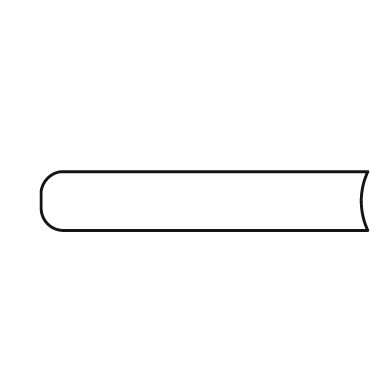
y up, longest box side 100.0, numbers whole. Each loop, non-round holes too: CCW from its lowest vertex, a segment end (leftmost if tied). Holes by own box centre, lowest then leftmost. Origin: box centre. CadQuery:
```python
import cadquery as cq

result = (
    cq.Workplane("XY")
    .moveTo(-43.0, -9.0)
    .lineTo(50.0, -9.0)
    .threePointArc((48.0, 0.0), (50.0, 9.0))
    .lineTo(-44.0, 9.0)
    .threePointArc((-48.0, 7.0), (-50.0, 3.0))
    .lineTo(-50.0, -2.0)
    .threePointArc((-48.0, -7.0), (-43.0, -9.0))
    .close()
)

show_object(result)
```